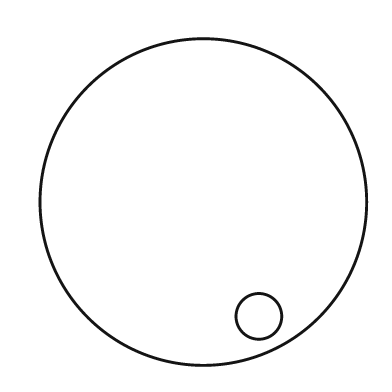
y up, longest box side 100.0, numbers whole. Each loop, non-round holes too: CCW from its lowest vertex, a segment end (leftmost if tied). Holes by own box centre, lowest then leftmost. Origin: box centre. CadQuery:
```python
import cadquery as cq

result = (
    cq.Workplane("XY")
    .moveTo(0.0, 0.0)
    .circle(50.0)
    .moveTo(17.0, -35.0)
    .circle(7.0)
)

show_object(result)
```